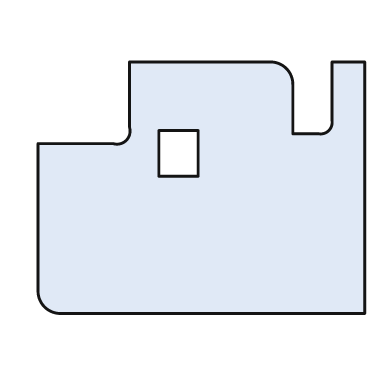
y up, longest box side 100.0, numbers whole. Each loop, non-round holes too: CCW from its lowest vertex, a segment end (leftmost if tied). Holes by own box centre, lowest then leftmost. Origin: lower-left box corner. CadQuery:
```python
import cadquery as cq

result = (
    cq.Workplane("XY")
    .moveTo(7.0, 0.0)
    .lineTo(100.0, 0.0)
    .lineTo(100.0, 77.0)
    .lineTo(90.0, 77.0)
    .lineTo(90.0, 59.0)
    .threePointArc((89.0, 56.0), (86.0, 55.0))
    .lineTo(78.0, 55.0)
    .lineTo(78.0, 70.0)
    .threePointArc((76.0, 75.0), (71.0, 77.0))
    .lineTo(28.0, 77.0)
    .lineTo(28.0, 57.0)
    .threePointArc((27.0, 53.0), (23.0, 52.0))
    .lineTo(0.0, 52.0)
    .lineTo(0.0, 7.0)
    .threePointArc((2.0, 2.0), (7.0, 0.0))
    .close()
    .moveTo(37.0, 42.0)
    .lineTo(49.0, 42.0)
    .lineTo(49.0, 56.0)
    .lineTo(37.0, 56.0)
    .close()
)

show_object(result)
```